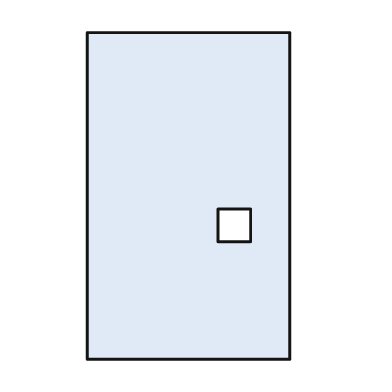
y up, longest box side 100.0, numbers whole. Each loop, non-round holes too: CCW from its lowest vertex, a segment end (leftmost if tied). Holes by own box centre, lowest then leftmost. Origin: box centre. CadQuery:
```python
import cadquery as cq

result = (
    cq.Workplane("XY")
    .moveTo(-31.0, -50.0)
    .lineTo(31.0, -50.0)
    .lineTo(31.0, 50.0)
    .lineTo(-31.0, 50.0)
    .close()
    .moveTo(9.0, -14.0)
    .lineTo(19.0, -14.0)
    .lineTo(19.0, -4.0)
    .lineTo(9.0, -4.0)
    .close()
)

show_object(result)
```